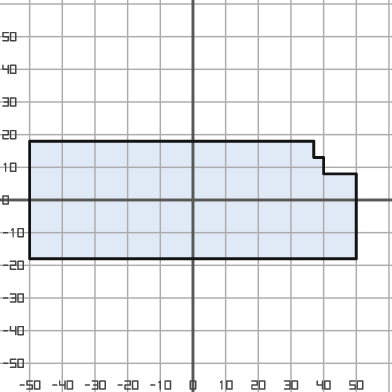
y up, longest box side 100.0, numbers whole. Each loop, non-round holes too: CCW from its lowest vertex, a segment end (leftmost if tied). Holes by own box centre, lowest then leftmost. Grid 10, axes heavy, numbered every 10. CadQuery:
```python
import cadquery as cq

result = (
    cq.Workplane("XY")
    .moveTo(-50.0, -18.0)
    .lineTo(50.0, -18.0)
    .lineTo(50.0, 8.0)
    .lineTo(40.0, 8.0)
    .lineTo(40.0, 13.0)
    .lineTo(37.0, 13.0)
    .lineTo(37.0, 18.0)
    .lineTo(-50.0, 18.0)
    .close()
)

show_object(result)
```